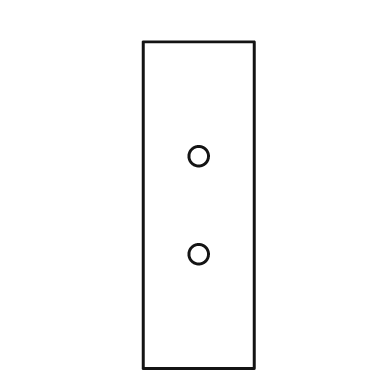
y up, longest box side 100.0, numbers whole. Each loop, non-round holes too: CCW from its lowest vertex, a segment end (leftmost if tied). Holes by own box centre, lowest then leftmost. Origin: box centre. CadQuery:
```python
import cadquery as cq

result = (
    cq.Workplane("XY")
    .moveTo(-17.0, -50.0)
    .lineTo(17.0, -50.0)
    .lineTo(17.0, 50.0)
    .lineTo(-17.0, 50.0)
    .close()
    .moveTo(0.0, -15.0)
    .circle(3.0)
    .moveTo(0.0, 15.0)
    .circle(3.0)
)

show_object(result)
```